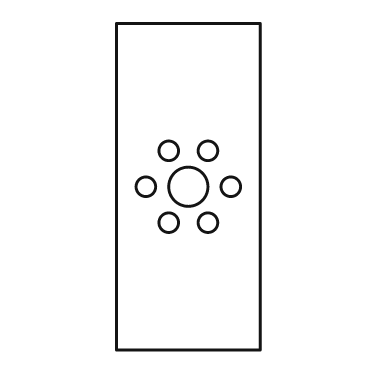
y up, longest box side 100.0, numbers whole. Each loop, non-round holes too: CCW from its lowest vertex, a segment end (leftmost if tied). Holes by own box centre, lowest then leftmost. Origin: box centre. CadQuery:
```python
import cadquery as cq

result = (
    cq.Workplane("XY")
    .moveTo(-22.0, -50.0)
    .lineTo(22.0, -50.0)
    .lineTo(22.0, 50.0)
    .lineTo(-22.0, 50.0)
    .close()
    .moveTo(-6.0, -11.0)
    .circle(3.0)
    .moveTo(6.0, -11.0)
    .circle(3.0)
    .moveTo(-13.0, 0.0)
    .circle(3.0)
    .moveTo(0.0, 0.0)
    .circle(6.0)
    .moveTo(13.0, 0.0)
    .circle(3.0)
    .moveTo(-6.0, 11.0)
    .circle(3.0)
    .moveTo(6.0, 11.0)
    .circle(3.0)
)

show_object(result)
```